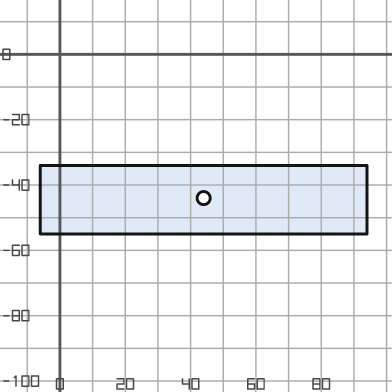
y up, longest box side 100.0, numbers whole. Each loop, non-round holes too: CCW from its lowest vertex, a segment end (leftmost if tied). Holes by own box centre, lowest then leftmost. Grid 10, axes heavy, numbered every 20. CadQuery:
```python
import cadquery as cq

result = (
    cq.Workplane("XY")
    .moveTo(-6.0, -55.0)
    .lineTo(94.0, -55.0)
    .lineTo(94.0, -34.0)
    .lineTo(-6.0, -34.0)
    .close()
    .moveTo(44.0, -44.0)
    .circle(2.0)
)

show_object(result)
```